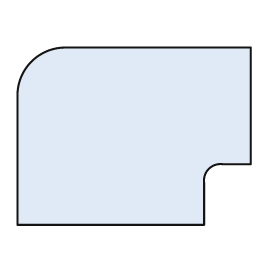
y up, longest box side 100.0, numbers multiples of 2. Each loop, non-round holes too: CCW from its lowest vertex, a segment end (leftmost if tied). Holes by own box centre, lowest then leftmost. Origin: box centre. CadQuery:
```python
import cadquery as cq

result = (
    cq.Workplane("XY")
    .moveTo(-50.0, -38.0)
    .lineTo(30.0, -38.0)
    .lineTo(30.0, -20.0)
    .threePointArc((32.0, -14.0), (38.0, -12.0))
    .lineTo(50.0, -12.0)
    .lineTo(50.0, 38.0)
    .lineTo(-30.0, 38.0)
    .threePointArc((-44.0, 32.0), (-50.0, 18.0))
    .close()
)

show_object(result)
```